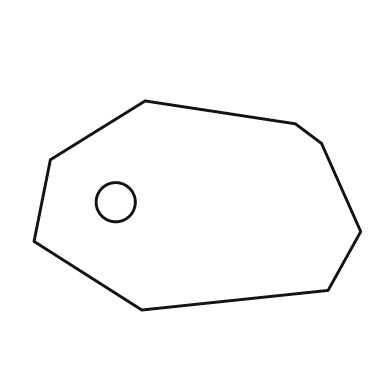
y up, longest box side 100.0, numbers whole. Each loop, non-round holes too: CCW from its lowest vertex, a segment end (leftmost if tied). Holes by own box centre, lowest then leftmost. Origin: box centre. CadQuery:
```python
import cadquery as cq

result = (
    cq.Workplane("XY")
    .moveTo(-17.0, -32.0)
    .lineTo(40.0, -26.0)
    .lineTo(50.0, -8.0)
    .lineTo(38.0, 19.0)
    .lineTo(30.0, 25.0)
    .lineTo(-16.0, 32.0)
    .lineTo(-45.0, 14.0)
    .lineTo(-50.0, -11.0)
    .close()
    .moveTo(-25.0, 1.0)
    .circle(6.0)
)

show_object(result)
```